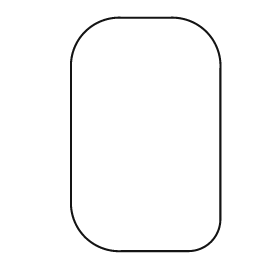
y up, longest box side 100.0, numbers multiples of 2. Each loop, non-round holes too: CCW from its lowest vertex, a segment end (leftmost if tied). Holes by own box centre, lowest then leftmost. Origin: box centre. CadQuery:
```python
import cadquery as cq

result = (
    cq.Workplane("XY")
    .moveTo(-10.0, -50.0)
    .lineTo(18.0, -50.0)
    .threePointArc((28.0, -46.0), (32.0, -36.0))
    .lineTo(32.0, 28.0)
    .threePointArc((26.0, 44.0), (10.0, 50.0))
    .lineTo(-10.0, 50.0)
    .threePointArc((-26.0, 44.0), (-32.0, 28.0))
    .lineTo(-32.0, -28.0)
    .threePointArc((-26.0, -44.0), (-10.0, -50.0))
    .close()
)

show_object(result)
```